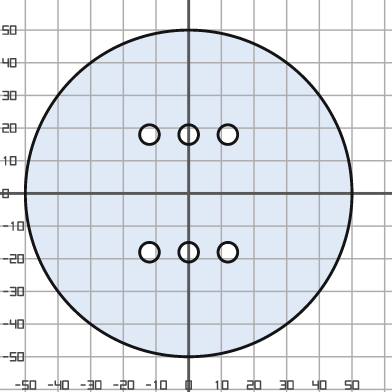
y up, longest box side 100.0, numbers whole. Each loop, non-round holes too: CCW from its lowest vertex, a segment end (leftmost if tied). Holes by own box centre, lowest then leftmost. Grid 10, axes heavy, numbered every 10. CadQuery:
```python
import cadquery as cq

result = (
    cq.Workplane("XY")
    .moveTo(0.0, 0.0)
    .circle(50.0)
    .moveTo(-12.0, -18.0)
    .circle(3.0)
    .moveTo(0.0, -18.0)
    .circle(3.0)
    .moveTo(12.0, -18.0)
    .circle(3.0)
    .moveTo(-12.0, 18.0)
    .circle(3.0)
    .moveTo(0.0, 18.0)
    .circle(3.0)
    .moveTo(12.0, 18.0)
    .circle(3.0)
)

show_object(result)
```